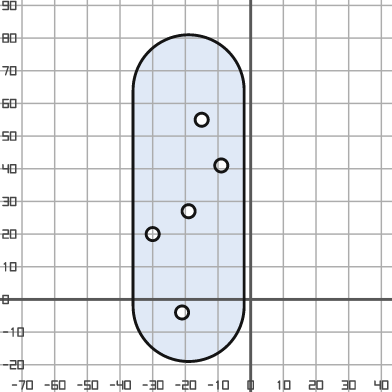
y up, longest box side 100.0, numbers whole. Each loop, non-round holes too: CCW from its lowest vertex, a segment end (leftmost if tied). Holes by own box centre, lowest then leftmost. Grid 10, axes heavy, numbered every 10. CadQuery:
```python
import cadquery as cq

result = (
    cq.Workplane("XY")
    .moveTo(-36.0, -2.0)
    .threePointArc((-19.0, -19.0), (-2.0, -2.0))
    .lineTo(-2.0, 64.0)
    .threePointArc((-19.0, 81.0), (-36.0, 64.0))
    .close()
    .moveTo(-21.0, -4.0)
    .circle(2.0)
    .moveTo(-30.0, 20.0)
    .circle(2.0)
    .moveTo(-19.0, 27.0)
    .circle(2.0)
    .moveTo(-9.0, 41.0)
    .circle(2.0)
    .moveTo(-15.0, 55.0)
    .circle(2.0)
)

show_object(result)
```